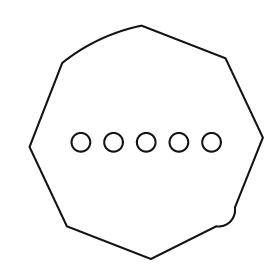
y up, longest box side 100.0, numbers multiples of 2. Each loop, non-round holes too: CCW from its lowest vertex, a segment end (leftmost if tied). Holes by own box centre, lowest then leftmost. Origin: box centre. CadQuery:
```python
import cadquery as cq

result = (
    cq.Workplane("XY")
    .moveTo(2.0, -50.0)
    .lineTo(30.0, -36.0)
    .threePointArc((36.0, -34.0), (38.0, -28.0))
    .lineTo(50.0, 2.0)
    .lineTo(34.0, 36.0)
    .lineTo(-2.0, 50.0)
    .threePointArc((-20.0, 44.0), (-36.0, 34.0))
    .lineTo(-50.0, -2.0)
    .lineTo(-34.0, -36.0)
    .close()
    .moveTo(-28.0, 0.0)
    .circle(4.0)
    .moveTo(-14.0, 0.0)
    .circle(4.0)
    .moveTo(0.0, 0.0)
    .circle(4.0)
    .moveTo(14.0, 0.0)
    .circle(4.0)
    .moveTo(28.0, 0.0)
    .circle(4.0)
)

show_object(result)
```